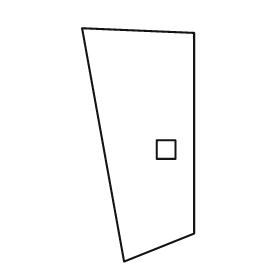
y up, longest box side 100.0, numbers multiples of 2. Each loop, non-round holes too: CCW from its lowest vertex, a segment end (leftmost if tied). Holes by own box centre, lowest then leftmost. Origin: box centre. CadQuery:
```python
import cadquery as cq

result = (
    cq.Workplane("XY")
    .moveTo(-6.0, -50.0)
    .lineTo(24.0, -38.0)
    .lineTo(24.0, 48.0)
    .lineTo(-24.0, 50.0)
    .close()
    .moveTo(8.0, -6.0)
    .lineTo(16.0, -6.0)
    .lineTo(16.0, 2.0)
    .lineTo(8.0, 2.0)
    .close()
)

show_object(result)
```